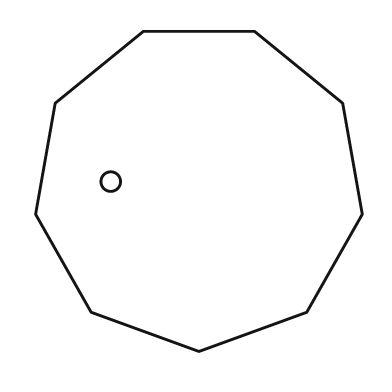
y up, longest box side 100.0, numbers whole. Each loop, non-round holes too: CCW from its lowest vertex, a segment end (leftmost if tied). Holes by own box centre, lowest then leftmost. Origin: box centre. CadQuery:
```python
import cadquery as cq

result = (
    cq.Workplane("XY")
    .moveTo(0.0, -49.0)
    .lineTo(33.0, -37.0)
    .lineTo(50.0, -7.0)
    .lineTo(44.0, 27.0)
    .lineTo(17.0, 49.0)
    .lineTo(-17.0, 49.0)
    .lineTo(-44.0, 27.0)
    .lineTo(-50.0, -7.0)
    .lineTo(-33.0, -37.0)
    .close()
    .moveTo(-27.0, 3.0)
    .circle(3.0)
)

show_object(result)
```